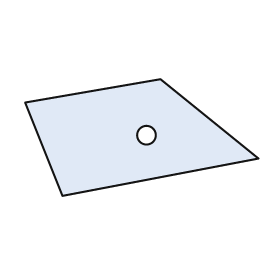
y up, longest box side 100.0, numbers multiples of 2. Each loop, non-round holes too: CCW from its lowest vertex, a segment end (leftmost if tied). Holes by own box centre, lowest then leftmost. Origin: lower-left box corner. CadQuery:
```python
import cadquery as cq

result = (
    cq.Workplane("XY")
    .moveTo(16.0, 0.0)
    .lineTo(100.0, 16.0)
    .lineTo(58.0, 50.0)
    .lineTo(0.0, 40.0)
    .close()
    .moveTo(52.0, 26.0)
    .circle(4.0)
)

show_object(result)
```